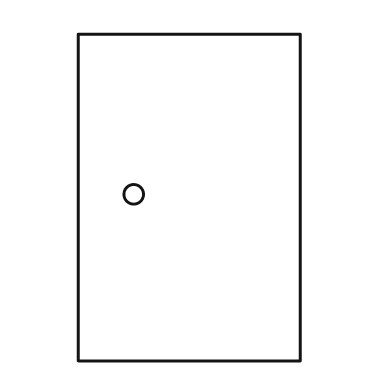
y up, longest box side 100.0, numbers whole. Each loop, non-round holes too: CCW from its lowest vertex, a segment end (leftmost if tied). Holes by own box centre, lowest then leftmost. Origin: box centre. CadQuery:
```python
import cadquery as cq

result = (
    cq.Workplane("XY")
    .moveTo(-34.0, -50.0)
    .lineTo(34.0, -50.0)
    .lineTo(34.0, 50.0)
    .lineTo(-34.0, 50.0)
    .close()
    .moveTo(-17.0, 1.0)
    .circle(3.0)
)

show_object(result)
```